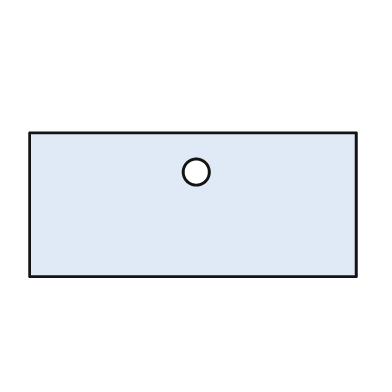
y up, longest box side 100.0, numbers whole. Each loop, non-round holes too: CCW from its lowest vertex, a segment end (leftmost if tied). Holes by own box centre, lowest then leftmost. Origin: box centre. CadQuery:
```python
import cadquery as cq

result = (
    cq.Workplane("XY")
    .moveTo(-50.0, -22.0)
    .lineTo(50.0, -22.0)
    .lineTo(50.0, 22.0)
    .lineTo(-50.0, 22.0)
    .close()
    .moveTo(1.0, 10.0)
    .circle(4.0)
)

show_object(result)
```